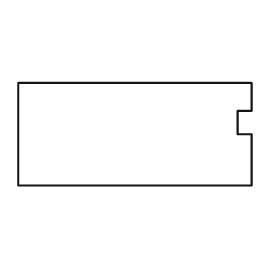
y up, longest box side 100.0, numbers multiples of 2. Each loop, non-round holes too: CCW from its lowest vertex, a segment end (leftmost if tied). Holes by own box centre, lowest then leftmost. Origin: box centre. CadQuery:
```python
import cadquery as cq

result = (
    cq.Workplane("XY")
    .moveTo(-50.0, -22.0)
    .lineTo(50.0, -22.0)
    .lineTo(50.0, 0.0)
    .lineTo(44.0, 0.0)
    .lineTo(44.0, 10.0)
    .lineTo(50.0, 10.0)
    .lineTo(50.0, 22.0)
    .lineTo(-50.0, 22.0)
    .close()
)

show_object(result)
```